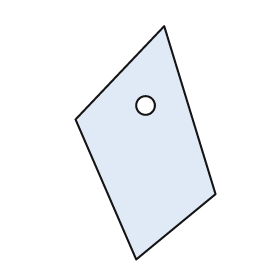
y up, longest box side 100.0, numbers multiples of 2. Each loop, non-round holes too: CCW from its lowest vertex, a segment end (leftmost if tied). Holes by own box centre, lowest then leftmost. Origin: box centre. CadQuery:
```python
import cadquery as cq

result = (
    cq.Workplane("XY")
    .moveTo(-4.0, -50.0)
    .lineTo(30.0, -22.0)
    .lineTo(8.0, 50.0)
    .lineTo(-30.0, 10.0)
    .close()
    .moveTo(0.0, 16.0)
    .circle(4.0)
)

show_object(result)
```